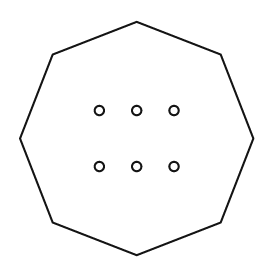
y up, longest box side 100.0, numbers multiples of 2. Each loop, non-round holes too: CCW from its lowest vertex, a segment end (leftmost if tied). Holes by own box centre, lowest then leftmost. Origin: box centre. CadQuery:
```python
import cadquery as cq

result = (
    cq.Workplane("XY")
    .moveTo(0.0, -50.0)
    .lineTo(36.0, -36.0)
    .lineTo(50.0, 0.0)
    .lineTo(36.0, 36.0)
    .lineTo(0.0, 50.0)
    .lineTo(-36.0, 36.0)
    .lineTo(-50.0, 0.0)
    .lineTo(-36.0, -36.0)
    .close()
    .moveTo(-16.0, -12.0)
    .circle(2.0)
    .moveTo(0.0, -12.0)
    .circle(2.0)
    .moveTo(16.0, -12.0)
    .circle(2.0)
    .moveTo(-16.0, 12.0)
    .circle(2.0)
    .moveTo(0.0, 12.0)
    .circle(2.0)
    .moveTo(16.0, 12.0)
    .circle(2.0)
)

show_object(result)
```